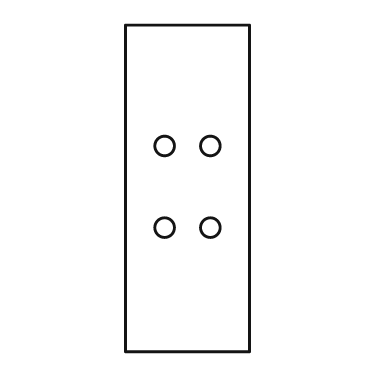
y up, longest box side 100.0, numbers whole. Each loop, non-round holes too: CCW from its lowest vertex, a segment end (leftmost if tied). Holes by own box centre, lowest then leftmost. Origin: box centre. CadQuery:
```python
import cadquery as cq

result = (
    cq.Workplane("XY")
    .moveTo(-19.0, -50.0)
    .lineTo(19.0, -50.0)
    .lineTo(19.0, 50.0)
    .lineTo(-19.0, 50.0)
    .close()
    .moveTo(-7.0, -12.0)
    .circle(3.0)
    .moveTo(7.0, -12.0)
    .circle(3.0)
    .moveTo(-7.0, 13.0)
    .circle(3.0)
    .moveTo(7.0, 13.0)
    .circle(3.0)
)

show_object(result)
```